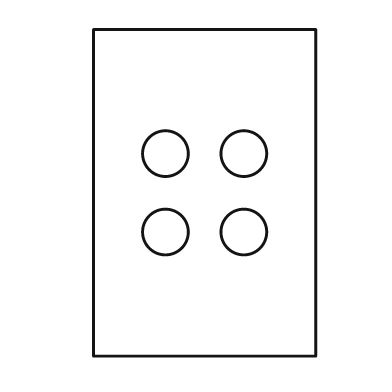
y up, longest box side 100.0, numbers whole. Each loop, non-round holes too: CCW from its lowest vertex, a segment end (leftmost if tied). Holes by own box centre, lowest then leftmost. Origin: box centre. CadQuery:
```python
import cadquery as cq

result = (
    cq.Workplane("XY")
    .moveTo(-34.0, -50.0)
    .lineTo(34.0, -50.0)
    .lineTo(34.0, 50.0)
    .lineTo(-34.0, 50.0)
    .close()
    .moveTo(-12.0, -12.0)
    .circle(7.0)
    .moveTo(12.0, -12.0)
    .circle(7.0)
    .moveTo(-12.0, 12.0)
    .circle(7.0)
    .moveTo(12.0, 12.0)
    .circle(7.0)
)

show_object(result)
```